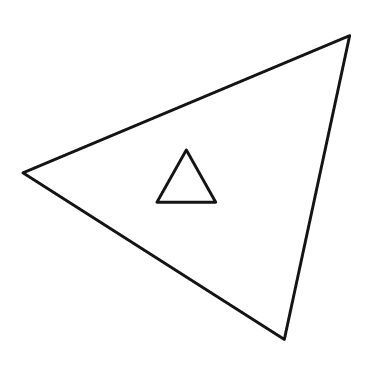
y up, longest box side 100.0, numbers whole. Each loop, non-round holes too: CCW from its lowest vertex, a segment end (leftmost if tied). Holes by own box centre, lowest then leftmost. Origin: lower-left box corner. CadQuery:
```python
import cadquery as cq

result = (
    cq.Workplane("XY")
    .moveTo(80.0, 0.0)
    .lineTo(100.0, 93.0)
    .lineTo(0.0, 51.0)
    .close()
    .moveTo(41.0, 42.0)
    .lineTo(59.0, 42.0)
    .lineTo(50.0, 58.0)
    .close()
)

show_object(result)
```